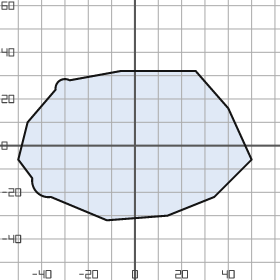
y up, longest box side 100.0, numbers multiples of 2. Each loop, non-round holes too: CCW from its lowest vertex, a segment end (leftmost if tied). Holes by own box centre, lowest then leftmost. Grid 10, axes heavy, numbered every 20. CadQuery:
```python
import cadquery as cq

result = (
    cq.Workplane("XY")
    .moveTo(-12.0, -32.0)
    .lineTo(14.0, -30.0)
    .lineTo(34.0, -22.0)
    .lineTo(50.0, -6.0)
    .lineTo(40.0, 16.0)
    .lineTo(26.0, 32.0)
    .lineTo(-6.0, 32.0)
    .lineTo(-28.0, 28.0)
    .threePointArc((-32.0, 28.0), (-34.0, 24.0))
    .lineTo(-46.0, 10.0)
    .lineTo(-50.0, -6.0)
    .lineTo(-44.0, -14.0)
    .threePointArc((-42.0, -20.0), (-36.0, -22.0))
    .close()
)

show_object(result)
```